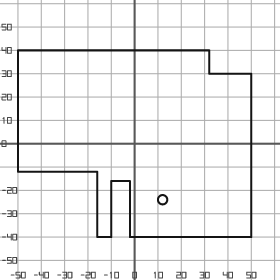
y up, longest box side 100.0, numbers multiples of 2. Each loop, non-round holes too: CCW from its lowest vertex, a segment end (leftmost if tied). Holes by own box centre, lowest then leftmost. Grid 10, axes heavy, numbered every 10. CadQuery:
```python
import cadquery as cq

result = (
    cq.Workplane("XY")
    .moveTo(-16.0, -40.0)
    .lineTo(-10.0, -40.0)
    .lineTo(-10.0, -16.0)
    .lineTo(-2.0, -16.0)
    .lineTo(-2.0, -40.0)
    .lineTo(50.0, -40.0)
    .lineTo(50.0, 30.0)
    .lineTo(32.0, 30.0)
    .lineTo(32.0, 40.0)
    .lineTo(-50.0, 40.0)
    .lineTo(-50.0, -12.0)
    .lineTo(-16.0, -12.0)
    .close()
    .moveTo(12.0, -24.0)
    .circle(2.0)
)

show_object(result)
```